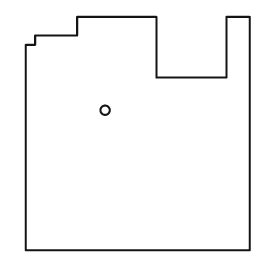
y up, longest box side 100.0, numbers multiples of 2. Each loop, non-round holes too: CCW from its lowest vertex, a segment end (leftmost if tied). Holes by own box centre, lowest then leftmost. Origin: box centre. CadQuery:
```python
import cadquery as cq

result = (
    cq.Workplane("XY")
    .moveTo(-48.0, -50.0)
    .lineTo(48.0, -50.0)
    .lineTo(48.0, 50.0)
    .lineTo(38.0, 50.0)
    .lineTo(38.0, 24.0)
    .lineTo(8.0, 24.0)
    .lineTo(8.0, 50.0)
    .lineTo(-26.0, 50.0)
    .lineTo(-26.0, 42.0)
    .lineTo(-44.0, 42.0)
    .lineTo(-44.0, 38.0)
    .lineTo(-48.0, 38.0)
    .close()
    .moveTo(-14.0, 10.0)
    .circle(2.0)
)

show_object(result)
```